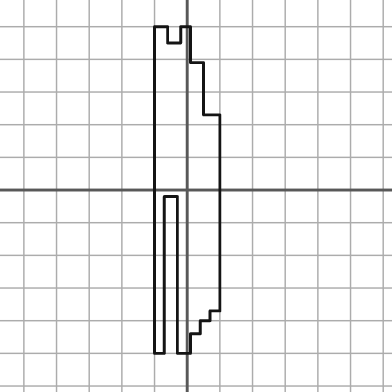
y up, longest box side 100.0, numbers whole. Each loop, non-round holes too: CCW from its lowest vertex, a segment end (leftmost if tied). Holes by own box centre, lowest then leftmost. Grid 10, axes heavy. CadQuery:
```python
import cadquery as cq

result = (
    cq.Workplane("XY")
    .moveTo(-10.0, -50.0)
    .lineTo(-7.0, -50.0)
    .lineTo(-7.0, -2.0)
    .lineTo(-3.0, -2.0)
    .lineTo(-3.0, -50.0)
    .lineTo(1.0, -50.0)
    .lineTo(1.0, -44.0)
    .lineTo(4.0, -44.0)
    .lineTo(4.0, -40.0)
    .lineTo(7.0, -40.0)
    .lineTo(7.0, -37.0)
    .lineTo(10.0, -37.0)
    .lineTo(10.0, 23.0)
    .lineTo(5.0, 23.0)
    .lineTo(5.0, 39.0)
    .lineTo(1.0, 39.0)
    .lineTo(1.0, 50.0)
    .lineTo(-2.0, 50.0)
    .lineTo(-2.0, 45.0)
    .lineTo(-6.0, 45.0)
    .lineTo(-6.0, 50.0)
    .lineTo(-10.0, 50.0)
    .close()
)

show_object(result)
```